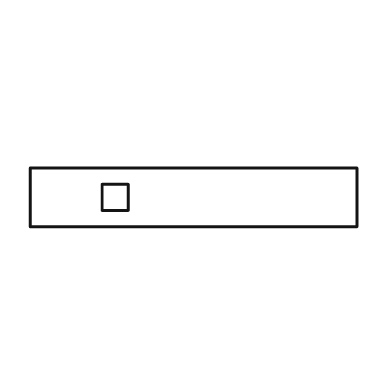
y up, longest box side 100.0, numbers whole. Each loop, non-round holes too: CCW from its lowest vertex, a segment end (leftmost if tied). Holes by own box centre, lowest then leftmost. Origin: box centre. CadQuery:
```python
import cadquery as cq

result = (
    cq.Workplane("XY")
    .moveTo(-50.0, -9.0)
    .lineTo(50.0, -9.0)
    .lineTo(50.0, 9.0)
    .lineTo(-50.0, 9.0)
    .close()
    .moveTo(-28.0, -4.0)
    .lineTo(-20.0, -4.0)
    .lineTo(-20.0, 4.0)
    .lineTo(-28.0, 4.0)
    .close()
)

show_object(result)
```